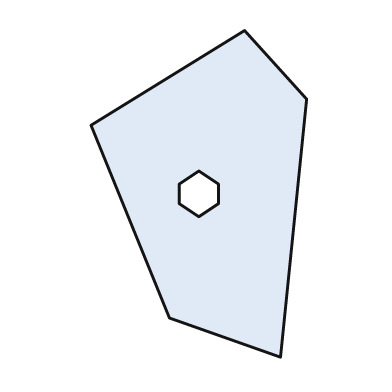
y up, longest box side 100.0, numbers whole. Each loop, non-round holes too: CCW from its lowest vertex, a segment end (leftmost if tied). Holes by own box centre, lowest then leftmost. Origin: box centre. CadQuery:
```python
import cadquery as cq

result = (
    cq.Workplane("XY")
    .moveTo(25.0, -50.0)
    .lineTo(33.0, 29.0)
    .lineTo(14.0, 50.0)
    .lineTo(-33.0, 21.0)
    .lineTo(-9.0, -38.0)
    .close()
    .moveTo(0.0, -7.0)
    .lineTo(6.0, -3.0)
    .lineTo(6.0, 3.0)
    .lineTo(0.0, 7.0)
    .lineTo(-6.0, 3.0)
    .lineTo(-6.0, -3.0)
    .close()
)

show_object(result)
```